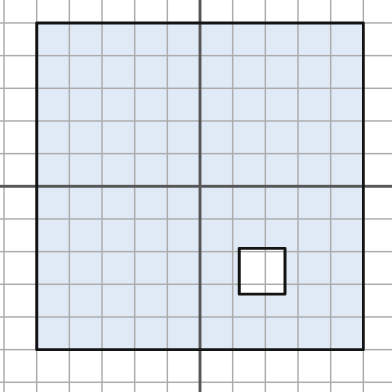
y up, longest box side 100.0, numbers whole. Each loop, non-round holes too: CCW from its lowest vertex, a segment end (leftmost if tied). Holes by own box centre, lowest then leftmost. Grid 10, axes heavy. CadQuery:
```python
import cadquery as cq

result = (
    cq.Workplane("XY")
    .moveTo(-50.0, -50.0)
    .lineTo(50.0, -50.0)
    .lineTo(50.0, 50.0)
    .lineTo(-50.0, 50.0)
    .close()
    .moveTo(12.0, -33.0)
    .lineTo(26.0, -33.0)
    .lineTo(26.0, -19.0)
    .lineTo(12.0, -19.0)
    .close()
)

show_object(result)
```